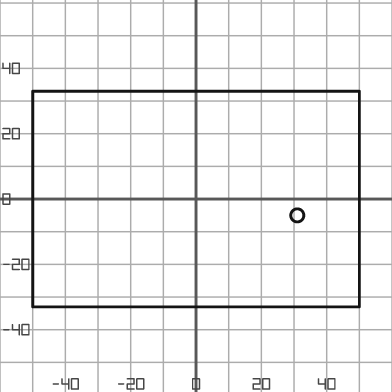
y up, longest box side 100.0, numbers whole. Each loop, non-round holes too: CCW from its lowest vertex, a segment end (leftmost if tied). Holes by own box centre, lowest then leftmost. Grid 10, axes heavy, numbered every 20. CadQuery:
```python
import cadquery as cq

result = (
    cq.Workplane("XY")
    .moveTo(-50.0, -33.0)
    .lineTo(50.0, -33.0)
    .lineTo(50.0, 33.0)
    .lineTo(-50.0, 33.0)
    .close()
    .moveTo(31.0, -5.0)
    .circle(2.0)
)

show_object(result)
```